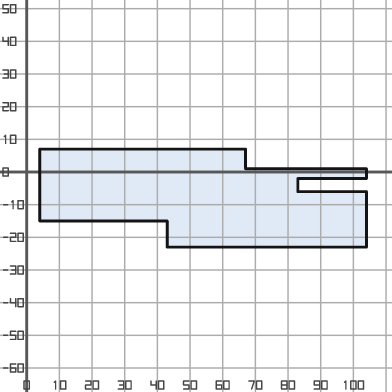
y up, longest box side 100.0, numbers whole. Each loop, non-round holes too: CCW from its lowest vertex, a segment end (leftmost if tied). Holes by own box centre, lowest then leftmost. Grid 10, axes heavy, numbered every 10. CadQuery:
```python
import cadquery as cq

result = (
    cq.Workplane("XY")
    .moveTo(43.0, -23.0)
    .lineTo(104.0, -23.0)
    .lineTo(104.0, -6.0)
    .lineTo(83.0, -6.0)
    .lineTo(83.0, -2.0)
    .lineTo(104.0, -2.0)
    .lineTo(104.0, 1.0)
    .lineTo(67.0, 1.0)
    .lineTo(67.0, 7.0)
    .lineTo(4.0, 7.0)
    .lineTo(4.0, -15.0)
    .lineTo(43.0, -15.0)
    .close()
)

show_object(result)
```